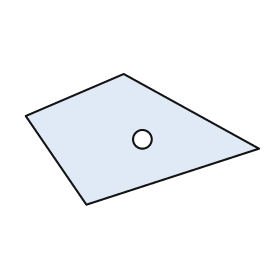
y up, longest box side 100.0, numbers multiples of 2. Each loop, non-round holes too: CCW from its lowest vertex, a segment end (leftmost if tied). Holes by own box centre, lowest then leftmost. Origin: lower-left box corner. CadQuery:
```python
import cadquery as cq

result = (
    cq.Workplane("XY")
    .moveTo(26.0, 0.0)
    .lineTo(100.0, 24.0)
    .lineTo(42.0, 56.0)
    .lineTo(0.0, 38.0)
    .close()
    .moveTo(50.0, 28.0)
    .circle(4.0)
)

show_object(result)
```